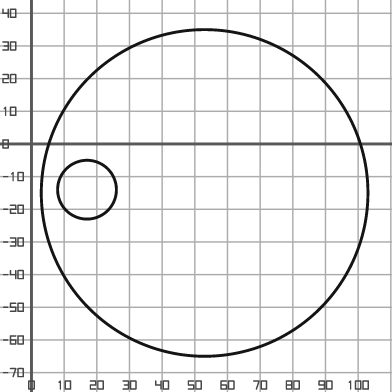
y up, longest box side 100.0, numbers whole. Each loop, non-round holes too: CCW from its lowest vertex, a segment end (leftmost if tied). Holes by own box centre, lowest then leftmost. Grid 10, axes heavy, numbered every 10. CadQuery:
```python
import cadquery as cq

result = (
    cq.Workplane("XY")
    .moveTo(53.0, -15.0)
    .circle(50.0)
    .moveTo(17.0, -14.0)
    .circle(9.0)
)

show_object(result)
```